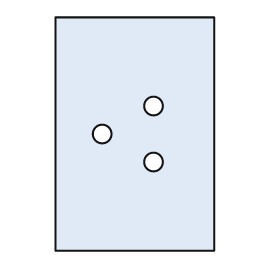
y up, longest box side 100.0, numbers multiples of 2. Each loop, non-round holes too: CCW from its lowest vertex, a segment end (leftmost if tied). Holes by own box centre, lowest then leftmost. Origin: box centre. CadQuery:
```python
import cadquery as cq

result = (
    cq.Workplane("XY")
    .moveTo(-34.0, -50.0)
    .lineTo(34.0, -50.0)
    .lineTo(34.0, 50.0)
    .lineTo(-34.0, 50.0)
    .close()
    .moveTo(8.0, -12.0)
    .circle(4.0)
    .moveTo(-14.0, 0.0)
    .circle(4.0)
    .moveTo(8.0, 12.0)
    .circle(4.0)
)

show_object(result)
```